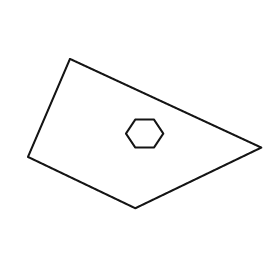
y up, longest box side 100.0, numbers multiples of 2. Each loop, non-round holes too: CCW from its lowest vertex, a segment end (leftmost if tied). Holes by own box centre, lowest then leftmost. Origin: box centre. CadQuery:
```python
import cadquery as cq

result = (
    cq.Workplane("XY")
    .moveTo(-4.0, -32.0)
    .lineTo(50.0, -6.0)
    .lineTo(-32.0, 32.0)
    .lineTo(-50.0, -10.0)
    .close()
    .moveTo(-4.0, -6.0)
    .lineTo(4.0, -6.0)
    .lineTo(8.0, 0.0)
    .lineTo(4.0, 6.0)
    .lineTo(-4.0, 6.0)
    .lineTo(-8.0, 0.0)
    .close()
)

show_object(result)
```